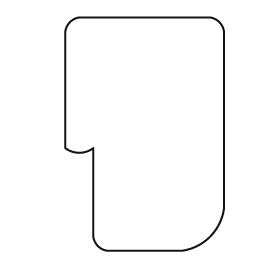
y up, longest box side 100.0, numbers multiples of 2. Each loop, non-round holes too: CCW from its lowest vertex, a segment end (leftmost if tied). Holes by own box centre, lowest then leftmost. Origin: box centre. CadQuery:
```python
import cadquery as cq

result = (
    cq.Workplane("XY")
    .moveTo(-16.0, -50.0)
    .lineTo(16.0, -50.0)
    .threePointArc((28.0, -44.0), (34.0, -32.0))
    .lineTo(34.0, 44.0)
    .threePointArc((32.0, 48.0), (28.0, 50.0))
    .lineTo(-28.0, 50.0)
    .threePointArc((-32.0, 48.0), (-34.0, 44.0))
    .lineTo(-34.0, -6.0)
    .threePointArc((-28.0, -8.0), (-22.0, -6.0))
    .lineTo(-22.0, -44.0)
    .threePointArc((-20.0, -48.0), (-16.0, -50.0))
    .close()
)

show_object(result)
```